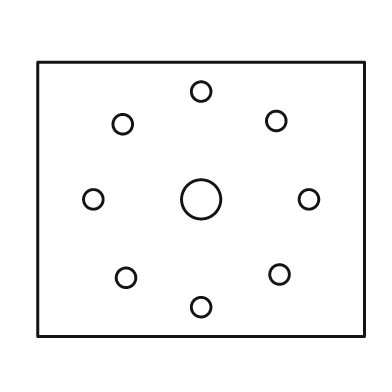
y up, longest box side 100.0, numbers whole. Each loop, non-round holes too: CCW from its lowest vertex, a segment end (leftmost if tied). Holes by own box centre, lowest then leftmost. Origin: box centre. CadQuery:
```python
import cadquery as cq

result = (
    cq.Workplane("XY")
    .moveTo(-50.0, -42.0)
    .lineTo(50.0, -42.0)
    .lineTo(50.0, 42.0)
    .lineTo(-50.0, 42.0)
    .close()
    .moveTo(0.0, -33.0)
    .circle(3.0)
    .moveTo(-23.0, -24.0)
    .circle(3.0)
    .moveTo(24.0, -23.0)
    .circle(3.0)
    .moveTo(-33.0, 0.0)
    .circle(3.0)
    .moveTo(0.0, 0.0)
    .circle(6.0)
    .moveTo(33.0, 0.0)
    .circle(3.0)
    .moveTo(-24.0, 23.0)
    .circle(3.0)
    .moveTo(23.0, 24.0)
    .circle(3.0)
    .moveTo(0.0, 33.0)
    .circle(3.0)
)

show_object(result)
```